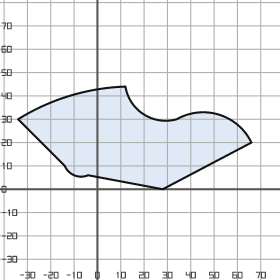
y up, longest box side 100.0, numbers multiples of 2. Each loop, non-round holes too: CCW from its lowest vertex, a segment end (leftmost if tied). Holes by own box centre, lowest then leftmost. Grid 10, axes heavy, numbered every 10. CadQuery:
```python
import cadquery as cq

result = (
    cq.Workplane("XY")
    .moveTo(28.0, 0.0)
    .lineTo(66.0, 20.0)
    .threePointArc((52.0, 32.0), (34.0, 30.0))
    .threePointArc((20.0, 32.0), (12.0, 44.0))
    .threePointArc((-12.0, 40.0), (-34.0, 30.0))
    .lineTo(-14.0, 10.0)
    .threePointArc((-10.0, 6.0), (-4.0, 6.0))
    .close()
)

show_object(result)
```